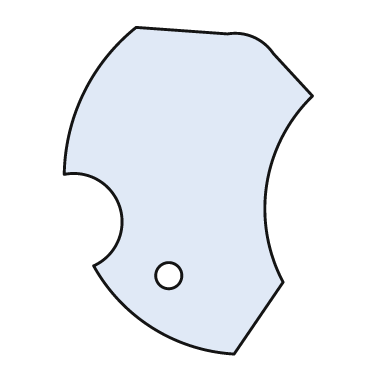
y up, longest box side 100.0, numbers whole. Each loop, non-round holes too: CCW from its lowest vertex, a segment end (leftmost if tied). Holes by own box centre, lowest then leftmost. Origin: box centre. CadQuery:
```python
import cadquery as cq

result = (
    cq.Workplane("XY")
    .moveTo(14.0, -50.0)
    .lineTo(29.0, -28.0)
    .threePointArc((24.0, 2.0), (38.0, 29.0))
    .lineTo(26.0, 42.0)
    .threePointArc((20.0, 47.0), (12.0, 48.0))
    .lineTo(-16.0, 50.0)
    .threePointArc((-32.0, 30.0), (-38.0, 5.0))
    .threePointArc((-21.0, -5.0), (-29.0, -23.0))
    .threePointArc((-11.0, -42.0), (14.0, -50.0))
    .close()
    .moveTo(-6.0, -26.0)
    .circle(4.0)
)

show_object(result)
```